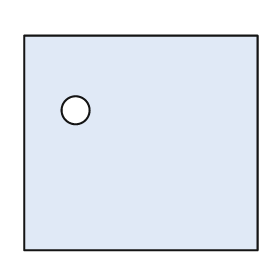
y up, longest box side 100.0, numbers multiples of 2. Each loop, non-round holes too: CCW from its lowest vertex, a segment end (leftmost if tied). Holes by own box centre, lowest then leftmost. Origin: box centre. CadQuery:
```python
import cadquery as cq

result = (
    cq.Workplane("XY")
    .moveTo(-50.0, -46.0)
    .lineTo(50.0, -46.0)
    .lineTo(50.0, 46.0)
    .lineTo(-50.0, 46.0)
    .close()
    .moveTo(-28.0, 14.0)
    .circle(6.0)
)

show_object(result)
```